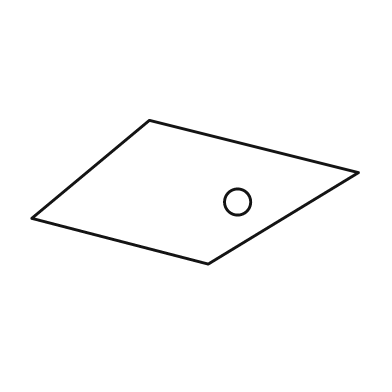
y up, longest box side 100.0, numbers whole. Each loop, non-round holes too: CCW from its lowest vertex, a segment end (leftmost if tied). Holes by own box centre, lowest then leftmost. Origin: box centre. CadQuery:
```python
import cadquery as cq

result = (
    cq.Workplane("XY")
    .moveTo(4.0, -22.0)
    .lineTo(50.0, 6.0)
    .lineTo(-14.0, 22.0)
    .lineTo(-50.0, -8.0)
    .close()
    .moveTo(13.0, -3.0)
    .circle(4.0)
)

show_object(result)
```